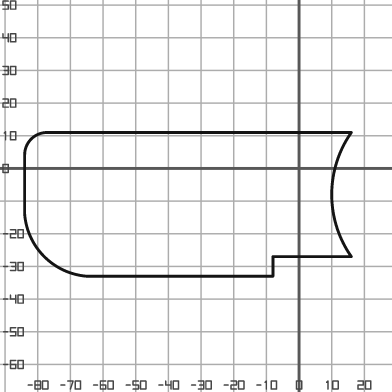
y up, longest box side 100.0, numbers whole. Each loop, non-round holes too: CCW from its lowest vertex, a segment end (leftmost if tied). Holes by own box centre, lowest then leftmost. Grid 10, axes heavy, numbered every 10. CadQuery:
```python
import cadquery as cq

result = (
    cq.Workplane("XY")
    .moveTo(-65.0, -33.0)
    .lineTo(-8.0, -33.0)
    .lineTo(-8.0, -27.0)
    .lineTo(16.0, -27.0)
    .threePointArc((10.0, -8.0), (16.0, 11.0))
    .lineTo(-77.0, 11.0)
    .threePointArc((-82.0, 9.0), (-84.0, 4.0))
    .lineTo(-84.0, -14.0)
    .threePointArc((-78.0, -27.0), (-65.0, -33.0))
    .close()
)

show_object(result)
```